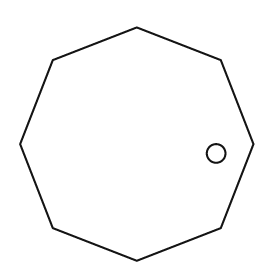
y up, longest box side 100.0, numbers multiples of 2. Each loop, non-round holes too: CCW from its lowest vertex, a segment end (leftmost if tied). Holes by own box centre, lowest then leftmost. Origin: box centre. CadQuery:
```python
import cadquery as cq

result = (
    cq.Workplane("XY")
    .moveTo(0.0, -50.0)
    .lineTo(36.0, -36.0)
    .lineTo(50.0, 0.0)
    .lineTo(36.0, 36.0)
    .lineTo(0.0, 50.0)
    .lineTo(-36.0, 36.0)
    .lineTo(-50.0, 0.0)
    .lineTo(-36.0, -36.0)
    .close()
    .moveTo(34.0, -4.0)
    .circle(4.0)
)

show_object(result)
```